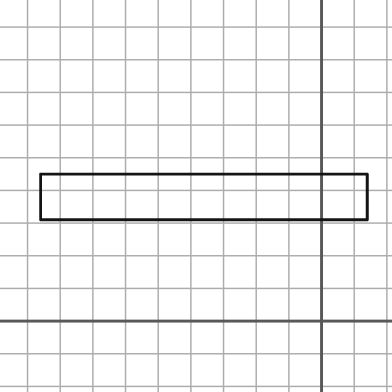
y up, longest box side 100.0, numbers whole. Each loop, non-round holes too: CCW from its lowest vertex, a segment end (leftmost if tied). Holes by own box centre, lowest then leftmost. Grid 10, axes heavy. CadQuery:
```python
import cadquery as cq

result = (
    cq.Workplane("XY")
    .moveTo(-86.0, 31.0)
    .lineTo(14.0, 31.0)
    .lineTo(14.0, 45.0)
    .lineTo(-86.0, 45.0)
    .close()
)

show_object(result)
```